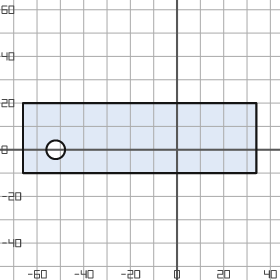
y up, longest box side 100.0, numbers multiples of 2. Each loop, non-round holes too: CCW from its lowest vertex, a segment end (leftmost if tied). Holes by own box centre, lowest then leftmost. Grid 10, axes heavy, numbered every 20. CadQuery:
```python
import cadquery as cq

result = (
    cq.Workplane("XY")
    .moveTo(-66.0, -10.0)
    .lineTo(34.0, -10.0)
    .lineTo(34.0, 20.0)
    .lineTo(-66.0, 20.0)
    .close()
    .moveTo(-52.0, 0.0)
    .circle(4.0)
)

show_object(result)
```